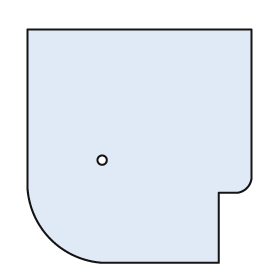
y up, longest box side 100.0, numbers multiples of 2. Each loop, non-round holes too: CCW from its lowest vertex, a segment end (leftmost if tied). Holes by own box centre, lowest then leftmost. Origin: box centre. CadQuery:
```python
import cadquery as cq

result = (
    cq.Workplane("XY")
    .moveTo(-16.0, -50.0)
    .lineTo(34.0, -50.0)
    .lineTo(34.0, -20.0)
    .lineTo(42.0, -20.0)
    .threePointArc((46.0, -18.0), (48.0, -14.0))
    .lineTo(48.0, 50.0)
    .lineTo(-48.0, 50.0)
    .lineTo(-48.0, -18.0)
    .threePointArc((-38.0, -40.0), (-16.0, -50.0))
    .close()
    .moveTo(-16.0, -6.0)
    .circle(2.0)
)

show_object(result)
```